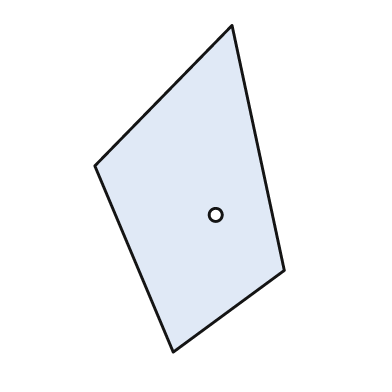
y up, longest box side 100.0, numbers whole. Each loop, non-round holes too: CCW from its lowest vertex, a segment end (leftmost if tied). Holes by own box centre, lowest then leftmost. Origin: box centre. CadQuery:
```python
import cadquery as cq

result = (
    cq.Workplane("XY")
    .moveTo(-5.0, -50.0)
    .lineTo(29.0, -25.0)
    .lineTo(13.0, 50.0)
    .lineTo(-29.0, 7.0)
    .close()
    .moveTo(8.0, -8.0)
    .circle(2.0)
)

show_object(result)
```